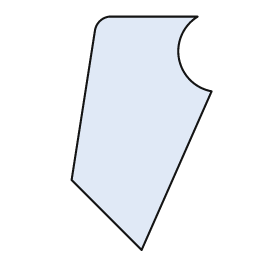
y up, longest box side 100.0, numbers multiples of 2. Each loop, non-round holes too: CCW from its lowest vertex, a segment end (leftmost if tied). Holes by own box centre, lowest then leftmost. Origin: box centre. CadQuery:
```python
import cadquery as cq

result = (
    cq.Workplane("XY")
    .moveTo(0.0, -50.0)
    .lineTo(30.0, 18.0)
    .threePointArc((16.0, 32.0), (24.0, 50.0))
    .lineTo(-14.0, 50.0)
    .threePointArc((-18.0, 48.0), (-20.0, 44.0))
    .lineTo(-30.0, -20.0)
    .close()
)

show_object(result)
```